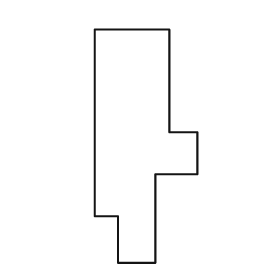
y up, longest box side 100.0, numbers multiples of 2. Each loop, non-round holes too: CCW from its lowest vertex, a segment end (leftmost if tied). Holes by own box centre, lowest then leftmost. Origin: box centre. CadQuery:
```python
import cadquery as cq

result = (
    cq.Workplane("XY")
    .moveTo(-12.0, -50.0)
    .lineTo(4.0, -50.0)
    .lineTo(4.0, -12.0)
    .lineTo(22.0, -12.0)
    .lineTo(22.0, 6.0)
    .lineTo(10.0, 6.0)
    .lineTo(10.0, 50.0)
    .lineTo(-22.0, 50.0)
    .lineTo(-22.0, -30.0)
    .lineTo(-12.0, -30.0)
    .close()
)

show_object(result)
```